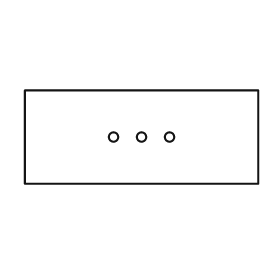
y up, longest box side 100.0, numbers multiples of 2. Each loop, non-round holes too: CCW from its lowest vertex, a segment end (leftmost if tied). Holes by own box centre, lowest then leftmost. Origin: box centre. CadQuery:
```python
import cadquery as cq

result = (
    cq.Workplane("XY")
    .moveTo(-50.0, -20.0)
    .lineTo(50.0, -20.0)
    .lineTo(50.0, 20.0)
    .lineTo(-50.0, 20.0)
    .close()
    .moveTo(-12.0, 0.0)
    .circle(2.0)
    .moveTo(0.0, 0.0)
    .circle(2.0)
    .moveTo(12.0, 0.0)
    .circle(2.0)
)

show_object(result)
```